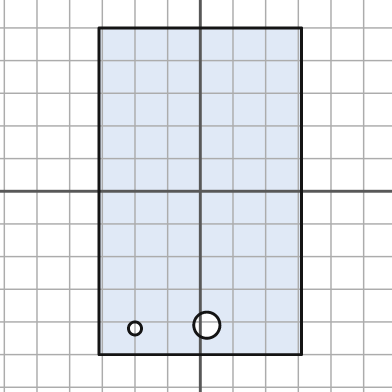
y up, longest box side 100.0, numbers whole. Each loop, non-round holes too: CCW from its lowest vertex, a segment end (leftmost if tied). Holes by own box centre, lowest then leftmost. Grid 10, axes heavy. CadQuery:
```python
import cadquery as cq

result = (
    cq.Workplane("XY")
    .moveTo(-31.0, -50.0)
    .lineTo(31.0, -50.0)
    .lineTo(31.0, 50.0)
    .lineTo(-31.0, 50.0)
    .close()
    .moveTo(-20.0, -42.0)
    .circle(2.0)
    .moveTo(2.0, -41.0)
    .circle(4.0)
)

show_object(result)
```